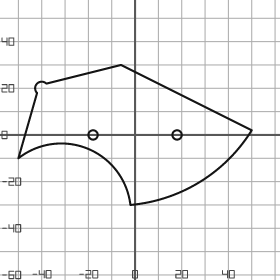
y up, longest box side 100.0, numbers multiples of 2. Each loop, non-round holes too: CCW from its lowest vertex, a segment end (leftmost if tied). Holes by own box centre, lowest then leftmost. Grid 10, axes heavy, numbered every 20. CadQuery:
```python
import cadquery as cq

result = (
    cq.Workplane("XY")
    .moveTo(-2.0, -30.0)
    .threePointArc((28.0, -20.0), (50.0, 2.0))
    .lineTo(-6.0, 30.0)
    .lineTo(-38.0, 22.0)
    .threePointArc((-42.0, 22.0), (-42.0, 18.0))
    .lineTo(-50.0, -10.0)
    .threePointArc((-20.0, -6.0), (-2.0, -30.0))
    .close()
    .moveTo(-18.0, 0.0)
    .circle(2.0)
    .moveTo(18.0, 0.0)
    .circle(2.0)
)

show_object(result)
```